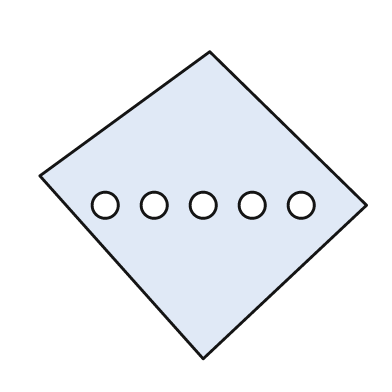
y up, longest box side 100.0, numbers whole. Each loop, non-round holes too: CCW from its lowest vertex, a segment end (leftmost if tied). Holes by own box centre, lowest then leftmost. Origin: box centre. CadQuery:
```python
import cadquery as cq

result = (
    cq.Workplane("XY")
    .moveTo(0.0, -47.0)
    .lineTo(50.0, 0.0)
    .lineTo(2.0, 47.0)
    .lineTo(-50.0, 9.0)
    .close()
    .moveTo(-30.0, 0.0)
    .circle(4.0)
    .moveTo(-15.0, 0.0)
    .circle(4.0)
    .moveTo(0.0, 0.0)
    .circle(4.0)
    .moveTo(15.0, 0.0)
    .circle(4.0)
    .moveTo(30.0, 0.0)
    .circle(4.0)
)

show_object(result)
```